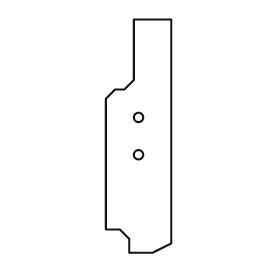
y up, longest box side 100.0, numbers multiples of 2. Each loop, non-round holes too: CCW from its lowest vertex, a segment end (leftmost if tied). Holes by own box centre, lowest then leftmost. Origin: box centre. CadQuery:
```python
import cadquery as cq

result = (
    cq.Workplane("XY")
    .moveTo(-4.0, -50.0)
    .lineTo(6.0, -50.0)
    .lineTo(14.0, -46.0)
    .lineTo(14.0, 50.0)
    .lineTo(-2.0, 50.0)
    .lineTo(-2.0, 24.0)
    .lineTo(-6.0, 20.0)
    .lineTo(-10.0, 20.0)
    .lineTo(-14.0, 16.0)
    .lineTo(-14.0, -40.0)
    .lineTo(-8.0, -40.0)
    .lineTo(-4.0, -44.0)
    .close()
    .moveTo(0.0, -8.0)
    .circle(2.0)
    .moveTo(0.0, 8.0)
    .circle(2.0)
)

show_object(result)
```